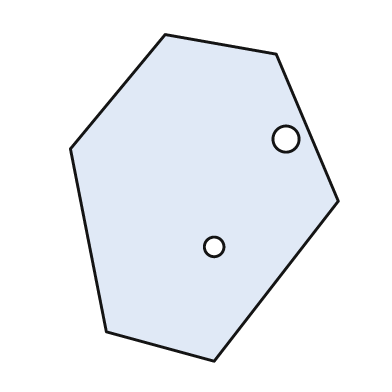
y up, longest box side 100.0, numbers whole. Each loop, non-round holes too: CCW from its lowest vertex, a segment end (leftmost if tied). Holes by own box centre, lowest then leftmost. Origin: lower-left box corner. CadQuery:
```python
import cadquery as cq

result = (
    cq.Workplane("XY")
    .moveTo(44.0, 0.0)
    .lineTo(82.0, 49.0)
    .lineTo(63.0, 94.0)
    .lineTo(29.0, 100.0)
    .lineTo(0.0, 65.0)
    .lineTo(11.0, 9.0)
    .close()
    .moveTo(44.0, 35.0)
    .circle(3.0)
    .moveTo(66.0, 68.0)
    .circle(4.0)
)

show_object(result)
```